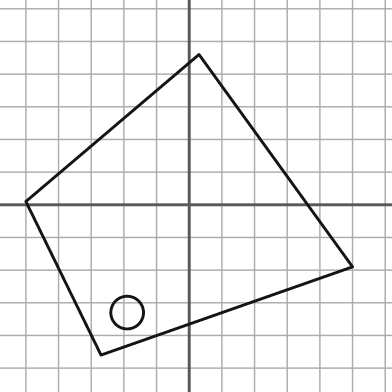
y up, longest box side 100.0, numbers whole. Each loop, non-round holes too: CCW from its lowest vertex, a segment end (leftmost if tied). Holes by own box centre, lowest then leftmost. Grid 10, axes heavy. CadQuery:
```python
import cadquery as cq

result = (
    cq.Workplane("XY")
    .moveTo(-27.0, -46.0)
    .lineTo(50.0, -19.0)
    .lineTo(3.0, 46.0)
    .lineTo(-50.0, 1.0)
    .close()
    .moveTo(-19.0, -33.0)
    .circle(5.0)
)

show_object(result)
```